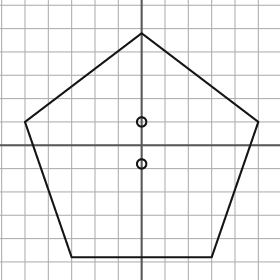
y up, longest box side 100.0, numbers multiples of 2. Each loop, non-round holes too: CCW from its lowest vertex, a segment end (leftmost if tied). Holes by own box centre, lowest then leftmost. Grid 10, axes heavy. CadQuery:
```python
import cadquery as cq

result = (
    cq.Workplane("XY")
    .moveTo(-30.0, -48.0)
    .lineTo(30.0, -48.0)
    .lineTo(50.0, 10.0)
    .lineTo(0.0, 48.0)
    .lineTo(-50.0, 10.0)
    .close()
    .moveTo(0.0, -8.0)
    .circle(2.0)
    .moveTo(0.0, 10.0)
    .circle(2.0)
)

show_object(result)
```